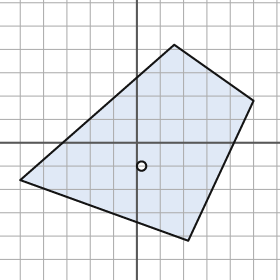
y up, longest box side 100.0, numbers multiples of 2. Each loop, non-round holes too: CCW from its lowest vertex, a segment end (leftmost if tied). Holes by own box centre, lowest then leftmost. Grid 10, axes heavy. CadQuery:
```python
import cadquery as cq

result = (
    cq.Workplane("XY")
    .moveTo(22.0, -42.0)
    .lineTo(50.0, 18.0)
    .lineTo(16.0, 42.0)
    .lineTo(-50.0, -16.0)
    .close()
    .moveTo(2.0, -10.0)
    .circle(2.0)
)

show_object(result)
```